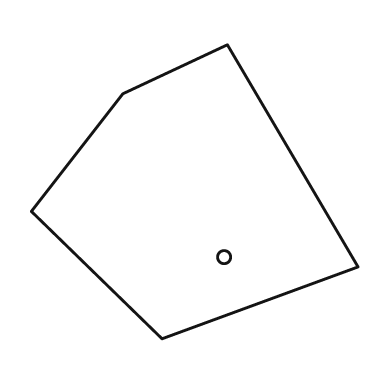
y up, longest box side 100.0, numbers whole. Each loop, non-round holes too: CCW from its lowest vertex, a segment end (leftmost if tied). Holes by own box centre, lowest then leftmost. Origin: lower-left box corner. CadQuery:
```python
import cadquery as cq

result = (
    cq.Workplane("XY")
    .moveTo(40.0, 0.0)
    .lineTo(100.0, 22.0)
    .lineTo(60.0, 90.0)
    .lineTo(28.0, 75.0)
    .lineTo(0.0, 39.0)
    .close()
    .moveTo(59.0, 25.0)
    .circle(2.0)
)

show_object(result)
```